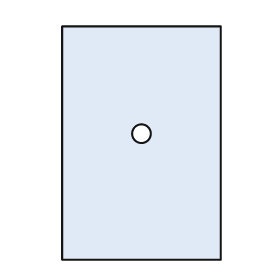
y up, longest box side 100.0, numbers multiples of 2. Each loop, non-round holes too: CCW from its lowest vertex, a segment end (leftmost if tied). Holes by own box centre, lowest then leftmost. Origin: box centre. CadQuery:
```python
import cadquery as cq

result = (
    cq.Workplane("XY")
    .moveTo(-34.0, -50.0)
    .lineTo(34.0, -50.0)
    .lineTo(34.0, 50.0)
    .lineTo(-34.0, 50.0)
    .close()
    .moveTo(0.0, 4.0)
    .circle(4.0)
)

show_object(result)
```